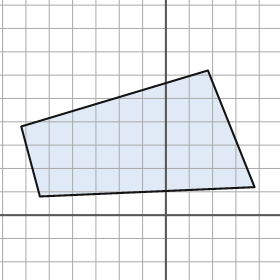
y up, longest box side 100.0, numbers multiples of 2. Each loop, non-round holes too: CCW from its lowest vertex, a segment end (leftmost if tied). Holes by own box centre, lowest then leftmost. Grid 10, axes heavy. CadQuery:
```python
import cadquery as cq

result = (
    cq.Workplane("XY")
    .moveTo(-54.0, 8.0)
    .lineTo(38.0, 12.0)
    .lineTo(18.0, 62.0)
    .lineTo(-62.0, 38.0)
    .close()
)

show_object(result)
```